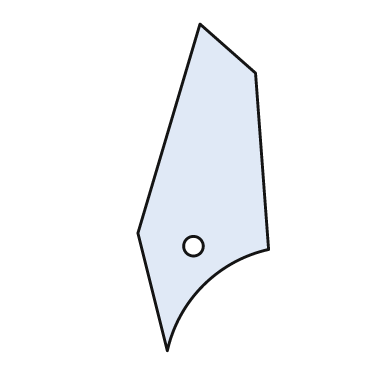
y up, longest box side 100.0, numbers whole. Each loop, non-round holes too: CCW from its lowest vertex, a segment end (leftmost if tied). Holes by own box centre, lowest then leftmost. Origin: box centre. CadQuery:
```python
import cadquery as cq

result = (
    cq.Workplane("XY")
    .moveTo(-11.0, -50.0)
    .threePointArc((0.0, -30.0), (20.0, -19.0))
    .lineTo(16.0, 35.0)
    .lineTo(-1.0, 50.0)
    .lineTo(-20.0, -14.0)
    .close()
    .moveTo(-3.0, -18.0)
    .circle(3.0)
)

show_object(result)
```